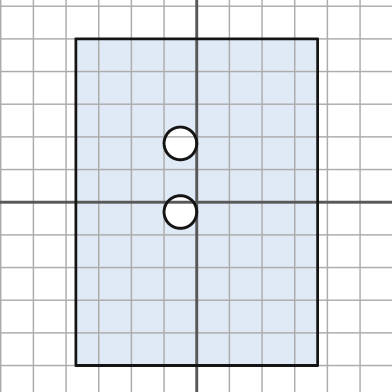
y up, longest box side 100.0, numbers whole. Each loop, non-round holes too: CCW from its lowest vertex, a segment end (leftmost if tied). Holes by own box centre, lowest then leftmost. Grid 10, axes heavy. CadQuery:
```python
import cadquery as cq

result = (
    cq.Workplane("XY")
    .moveTo(-37.0, -50.0)
    .lineTo(37.0, -50.0)
    .lineTo(37.0, 50.0)
    .lineTo(-37.0, 50.0)
    .close()
    .moveTo(-5.0, -3.0)
    .circle(5.0)
    .moveTo(-5.0, 18.0)
    .circle(5.0)
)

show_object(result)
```